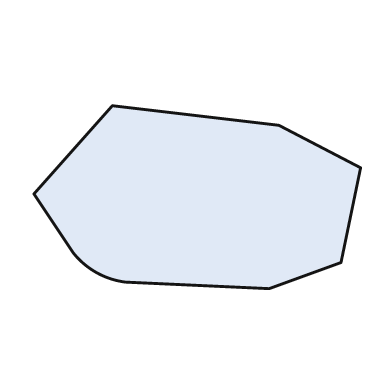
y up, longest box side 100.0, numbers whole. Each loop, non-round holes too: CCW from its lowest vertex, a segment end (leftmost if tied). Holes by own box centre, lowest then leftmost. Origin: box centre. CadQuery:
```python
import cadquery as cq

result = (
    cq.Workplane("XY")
    .moveTo(22.0, -28.0)
    .lineTo(44.0, -20.0)
    .lineTo(50.0, 9.0)
    .lineTo(25.0, 22.0)
    .lineTo(-26.0, 28.0)
    .lineTo(-50.0, 1.0)
    .lineTo(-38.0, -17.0)
    .threePointArc((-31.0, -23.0), (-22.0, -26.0))
    .close()
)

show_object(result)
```